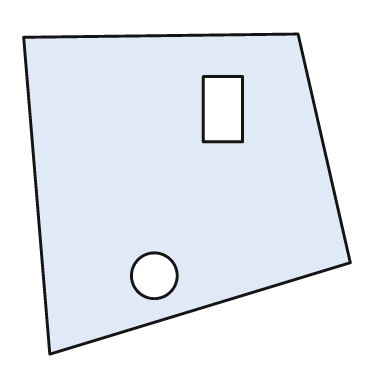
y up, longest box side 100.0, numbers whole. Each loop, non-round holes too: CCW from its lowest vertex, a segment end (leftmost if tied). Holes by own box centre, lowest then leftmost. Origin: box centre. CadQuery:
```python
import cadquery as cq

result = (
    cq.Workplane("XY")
    .moveTo(-42.0, -49.0)
    .lineTo(50.0, -21.0)
    .lineTo(34.0, 49.0)
    .lineTo(-50.0, 48.0)
    .close()
    .moveTo(-10.0, -25.0)
    .circle(7.0)
    .moveTo(5.0, 16.0)
    .lineTo(17.0, 16.0)
    .lineTo(17.0, 36.0)
    .lineTo(5.0, 36.0)
    .close()
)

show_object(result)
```